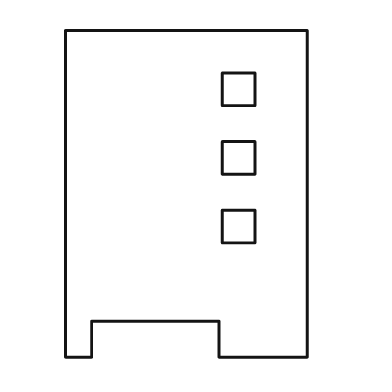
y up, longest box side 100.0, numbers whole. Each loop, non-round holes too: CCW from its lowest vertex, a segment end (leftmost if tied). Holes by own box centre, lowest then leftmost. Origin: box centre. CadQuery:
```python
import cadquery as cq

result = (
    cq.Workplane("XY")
    .moveTo(-37.0, -50.0)
    .lineTo(-29.0, -50.0)
    .lineTo(-29.0, -39.0)
    .lineTo(10.0, -39.0)
    .lineTo(10.0, -50.0)
    .lineTo(37.0, -50.0)
    .lineTo(37.0, 50.0)
    .lineTo(-37.0, 50.0)
    .close()
    .moveTo(11.0, -15.0)
    .lineTo(21.0, -15.0)
    .lineTo(21.0, -5.0)
    .lineTo(11.0, -5.0)
    .close()
    .moveTo(11.0, 6.0)
    .lineTo(21.0, 6.0)
    .lineTo(21.0, 16.0)
    .lineTo(11.0, 16.0)
    .close()
    .moveTo(11.0, 27.0)
    .lineTo(21.0, 27.0)
    .lineTo(21.0, 37.0)
    .lineTo(11.0, 37.0)
    .close()
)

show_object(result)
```